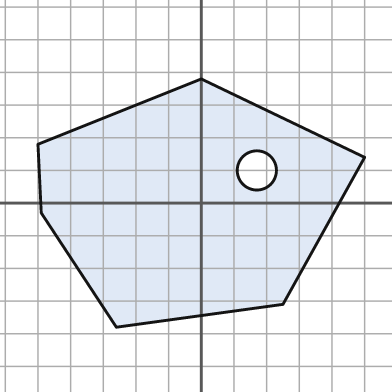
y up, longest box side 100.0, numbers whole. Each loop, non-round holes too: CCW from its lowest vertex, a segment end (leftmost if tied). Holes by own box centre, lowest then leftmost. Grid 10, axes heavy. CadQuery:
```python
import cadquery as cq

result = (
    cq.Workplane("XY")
    .moveTo(-26.0, -38.0)
    .lineTo(25.0, -31.0)
    .lineTo(50.0, 14.0)
    .lineTo(0.0, 38.0)
    .lineTo(-50.0, 18.0)
    .lineTo(-49.0, -3.0)
    .close()
    .moveTo(17.0, 10.0)
    .circle(6.0)
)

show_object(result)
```